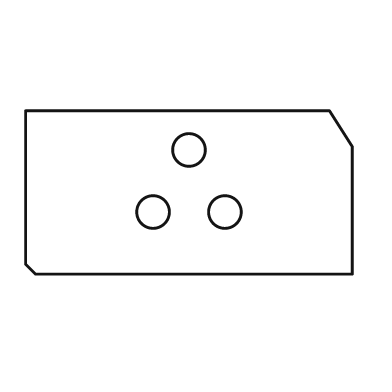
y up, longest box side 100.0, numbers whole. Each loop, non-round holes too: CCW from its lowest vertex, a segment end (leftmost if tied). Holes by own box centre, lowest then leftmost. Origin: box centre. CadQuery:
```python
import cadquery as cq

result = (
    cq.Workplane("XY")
    .moveTo(-47.0, -25.0)
    .lineTo(50.0, -25.0)
    .lineTo(50.0, 14.0)
    .lineTo(43.0, 25.0)
    .lineTo(-50.0, 25.0)
    .lineTo(-50.0, -22.0)
    .close()
    .moveTo(-11.0, -6.0)
    .circle(5.0)
    .moveTo(11.0, -6.0)
    .circle(5.0)
    .moveTo(0.0, 13.0)
    .circle(5.0)
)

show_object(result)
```